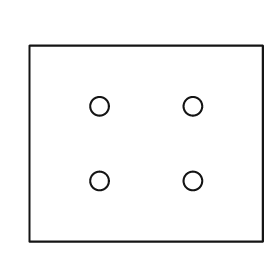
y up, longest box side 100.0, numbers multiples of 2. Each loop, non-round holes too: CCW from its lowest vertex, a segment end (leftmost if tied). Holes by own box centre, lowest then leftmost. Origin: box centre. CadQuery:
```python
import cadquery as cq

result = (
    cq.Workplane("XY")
    .moveTo(-50.0, -42.0)
    .lineTo(50.0, -42.0)
    .lineTo(50.0, 42.0)
    .lineTo(-50.0, 42.0)
    .close()
    .moveTo(-20.0, -16.0)
    .circle(4.0)
    .moveTo(20.0, -16.0)
    .circle(4.0)
    .moveTo(-20.0, 16.0)
    .circle(4.0)
    .moveTo(20.0, 16.0)
    .circle(4.0)
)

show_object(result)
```